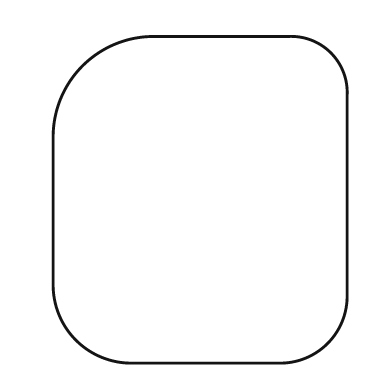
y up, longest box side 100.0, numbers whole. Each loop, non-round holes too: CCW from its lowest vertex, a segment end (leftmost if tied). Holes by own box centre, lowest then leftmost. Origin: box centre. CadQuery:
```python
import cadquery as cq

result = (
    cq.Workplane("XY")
    .moveTo(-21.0, -50.0)
    .lineTo(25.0, -50.0)
    .threePointArc((39.0, -44.0), (45.0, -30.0))
    .lineTo(45.0, 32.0)
    .threePointArc((40.0, 45.0), (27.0, 50.0))
    .lineTo(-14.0, 50.0)
    .threePointArc((-36.0, 41.0), (-45.0, 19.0))
    .lineTo(-45.0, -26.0)
    .threePointArc((-38.0, -43.0), (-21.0, -50.0))
    .close()
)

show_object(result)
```